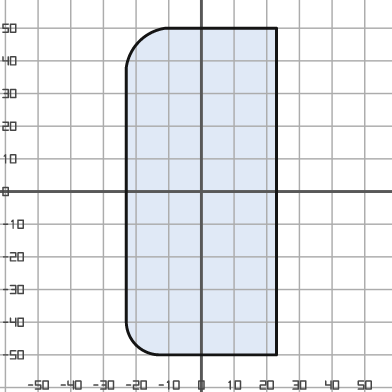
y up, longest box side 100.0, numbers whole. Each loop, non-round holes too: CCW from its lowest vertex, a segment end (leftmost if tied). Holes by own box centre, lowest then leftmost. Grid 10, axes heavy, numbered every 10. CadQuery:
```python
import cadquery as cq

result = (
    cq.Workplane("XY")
    .moveTo(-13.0, -50.0)
    .lineTo(23.0, -50.0)
    .lineTo(23.0, 50.0)
    .lineTo(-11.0, 50.0)
    .threePointArc((-19.0, 46.0), (-23.0, 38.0))
    .lineTo(-23.0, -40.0)
    .threePointArc((-20.0, -47.0), (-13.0, -50.0))
    .close()
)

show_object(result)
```